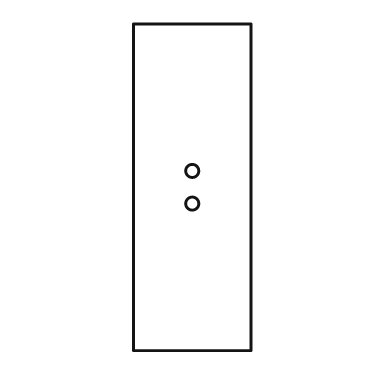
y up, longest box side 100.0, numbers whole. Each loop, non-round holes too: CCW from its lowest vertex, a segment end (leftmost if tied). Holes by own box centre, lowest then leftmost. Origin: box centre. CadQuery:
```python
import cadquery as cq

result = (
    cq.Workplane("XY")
    .moveTo(-18.0, -50.0)
    .lineTo(18.0, -50.0)
    .lineTo(18.0, 50.0)
    .lineTo(-18.0, 50.0)
    .close()
    .moveTo(0.0, -5.0)
    .circle(2.0)
    .moveTo(0.0, 5.0)
    .circle(2.0)
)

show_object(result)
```